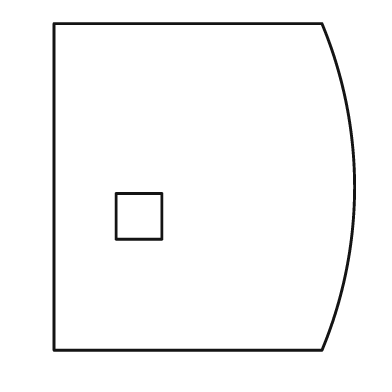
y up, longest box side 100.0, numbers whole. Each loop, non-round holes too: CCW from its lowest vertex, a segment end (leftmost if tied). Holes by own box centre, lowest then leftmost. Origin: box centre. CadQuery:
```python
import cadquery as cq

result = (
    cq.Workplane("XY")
    .moveTo(-46.0, -50.0)
    .lineTo(36.0, -50.0)
    .threePointArc((46.0, 0.0), (36.0, 50.0))
    .lineTo(-46.0, 50.0)
    .close()
    .moveTo(-27.0, -16.0)
    .lineTo(-13.0, -16.0)
    .lineTo(-13.0, -2.0)
    .lineTo(-27.0, -2.0)
    .close()
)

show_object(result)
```